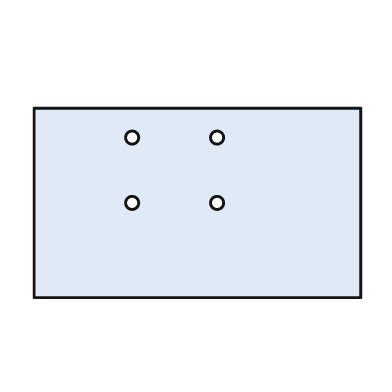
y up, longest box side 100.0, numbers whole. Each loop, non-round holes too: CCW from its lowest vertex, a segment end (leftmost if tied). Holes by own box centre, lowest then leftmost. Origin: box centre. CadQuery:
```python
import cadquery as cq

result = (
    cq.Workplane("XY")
    .moveTo(-50.0, -29.0)
    .lineTo(50.0, -29.0)
    .lineTo(50.0, 29.0)
    .lineTo(-50.0, 29.0)
    .close()
    .moveTo(-20.0, 0.0)
    .circle(2.0)
    .moveTo(6.0, 0.0)
    .circle(2.0)
    .moveTo(-20.0, 20.0)
    .circle(2.0)
    .moveTo(6.0, 20.0)
    .circle(2.0)
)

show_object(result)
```